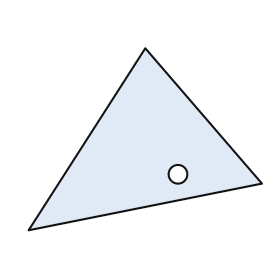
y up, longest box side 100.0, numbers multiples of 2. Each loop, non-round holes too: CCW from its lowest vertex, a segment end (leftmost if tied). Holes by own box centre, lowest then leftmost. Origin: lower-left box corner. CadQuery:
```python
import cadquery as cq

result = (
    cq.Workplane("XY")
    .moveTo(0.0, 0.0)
    .lineTo(100.0, 20.0)
    .lineTo(50.0, 78.0)
    .close()
    .moveTo(64.0, 24.0)
    .circle(4.0)
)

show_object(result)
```